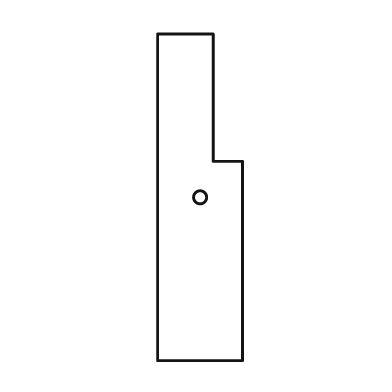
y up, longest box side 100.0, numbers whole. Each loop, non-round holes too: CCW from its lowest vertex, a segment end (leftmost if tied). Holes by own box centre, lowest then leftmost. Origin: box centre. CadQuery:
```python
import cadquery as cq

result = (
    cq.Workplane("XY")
    .moveTo(-13.0, -50.0)
    .lineTo(13.0, -50.0)
    .lineTo(13.0, 11.0)
    .lineTo(4.0, 11.0)
    .lineTo(4.0, 50.0)
    .lineTo(-13.0, 50.0)
    .close()
    .moveTo(0.0, 0.0)
    .circle(2.0)
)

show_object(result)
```